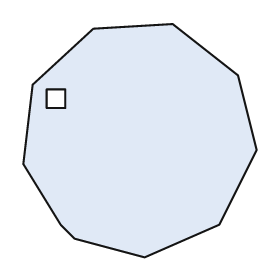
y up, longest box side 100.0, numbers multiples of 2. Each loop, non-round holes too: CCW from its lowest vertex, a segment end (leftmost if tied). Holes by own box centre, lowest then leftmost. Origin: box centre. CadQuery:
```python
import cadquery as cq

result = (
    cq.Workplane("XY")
    .moveTo(2.0, -50.0)
    .lineTo(34.0, -36.0)
    .lineTo(50.0, -4.0)
    .lineTo(42.0, 28.0)
    .lineTo(14.0, 50.0)
    .lineTo(-20.0, 48.0)
    .lineTo(-46.0, 24.0)
    .lineTo(-50.0, -10.0)
    .lineTo(-34.0, -36.0)
    .lineTo(-28.0, -42.0)
    .close()
    .moveTo(-40.0, 14.0)
    .lineTo(-32.0, 14.0)
    .lineTo(-32.0, 22.0)
    .lineTo(-40.0, 22.0)
    .close()
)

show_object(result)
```